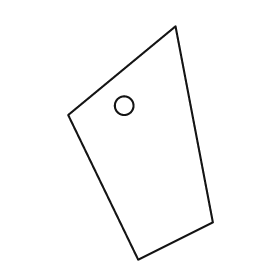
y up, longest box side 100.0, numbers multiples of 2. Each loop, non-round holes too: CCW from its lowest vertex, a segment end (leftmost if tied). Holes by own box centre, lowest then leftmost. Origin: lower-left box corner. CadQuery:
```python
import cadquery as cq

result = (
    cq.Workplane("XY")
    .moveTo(30.0, 0.0)
    .lineTo(62.0, 16.0)
    .lineTo(46.0, 100.0)
    .lineTo(0.0, 62.0)
    .close()
    .moveTo(24.0, 66.0)
    .circle(4.0)
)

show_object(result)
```